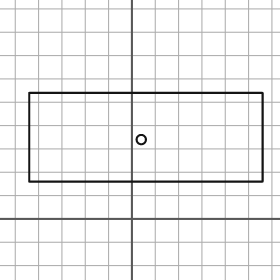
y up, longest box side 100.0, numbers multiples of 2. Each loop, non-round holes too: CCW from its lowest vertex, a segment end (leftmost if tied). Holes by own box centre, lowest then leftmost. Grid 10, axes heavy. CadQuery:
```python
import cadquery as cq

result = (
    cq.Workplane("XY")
    .moveTo(-44.0, 16.0)
    .lineTo(56.0, 16.0)
    .lineTo(56.0, 54.0)
    .lineTo(-44.0, 54.0)
    .close()
    .moveTo(4.0, 34.0)
    .circle(2.0)
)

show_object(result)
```